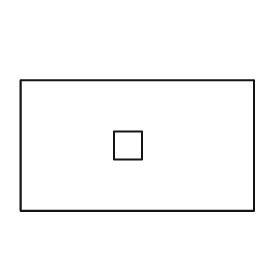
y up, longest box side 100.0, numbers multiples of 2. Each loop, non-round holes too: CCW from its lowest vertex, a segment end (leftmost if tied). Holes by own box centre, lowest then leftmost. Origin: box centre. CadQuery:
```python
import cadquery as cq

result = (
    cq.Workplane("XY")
    .moveTo(-50.0, -28.0)
    .lineTo(50.0, -28.0)
    .lineTo(50.0, 28.0)
    .lineTo(-50.0, 28.0)
    .close()
    .moveTo(-10.0, -6.0)
    .lineTo(2.0, -6.0)
    .lineTo(2.0, 6.0)
    .lineTo(-10.0, 6.0)
    .close()
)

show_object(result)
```